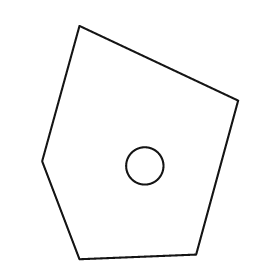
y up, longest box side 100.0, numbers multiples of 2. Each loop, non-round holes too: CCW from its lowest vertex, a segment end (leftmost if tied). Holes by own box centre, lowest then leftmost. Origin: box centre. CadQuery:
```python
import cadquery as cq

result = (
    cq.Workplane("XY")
    .moveTo(-26.0, -50.0)
    .lineTo(24.0, -48.0)
    .lineTo(42.0, 18.0)
    .lineTo(-26.0, 50.0)
    .lineTo(-42.0, -8.0)
    .close()
    .moveTo(2.0, -10.0)
    .circle(8.0)
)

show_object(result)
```